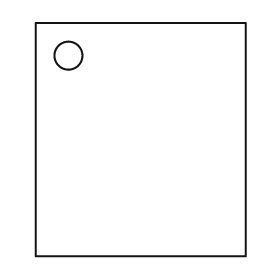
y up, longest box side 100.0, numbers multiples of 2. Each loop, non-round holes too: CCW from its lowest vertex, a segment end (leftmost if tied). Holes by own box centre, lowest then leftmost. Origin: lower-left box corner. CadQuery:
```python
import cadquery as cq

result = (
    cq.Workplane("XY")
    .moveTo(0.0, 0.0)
    .lineTo(90.0, 0.0)
    .lineTo(90.0, 100.0)
    .lineTo(0.0, 100.0)
    .close()
    .moveTo(14.0, 86.0)
    .circle(6.0)
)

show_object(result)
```